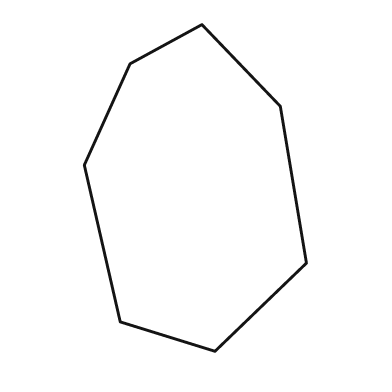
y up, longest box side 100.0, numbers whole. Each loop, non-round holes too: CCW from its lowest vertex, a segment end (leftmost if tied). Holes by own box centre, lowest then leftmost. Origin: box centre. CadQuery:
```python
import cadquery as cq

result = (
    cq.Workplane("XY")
    .moveTo(6.0, -50.0)
    .lineTo(34.0, -23.0)
    .lineTo(26.0, 25.0)
    .lineTo(2.0, 50.0)
    .lineTo(-20.0, 38.0)
    .lineTo(-34.0, 7.0)
    .lineTo(-23.0, -41.0)
    .close()
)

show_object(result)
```